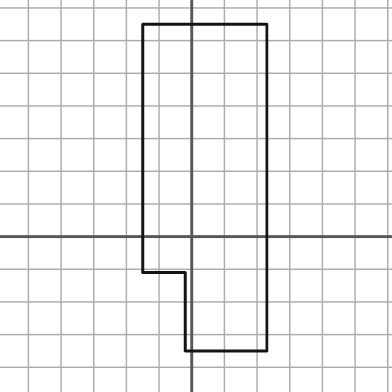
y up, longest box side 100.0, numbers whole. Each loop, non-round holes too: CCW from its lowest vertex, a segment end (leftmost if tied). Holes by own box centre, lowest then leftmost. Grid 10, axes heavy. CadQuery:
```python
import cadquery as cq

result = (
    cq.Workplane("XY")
    .moveTo(-2.0, -35.0)
    .lineTo(23.0, -35.0)
    .lineTo(23.0, 65.0)
    .lineTo(-15.0, 65.0)
    .lineTo(-15.0, -11.0)
    .lineTo(-2.0, -11.0)
    .close()
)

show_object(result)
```